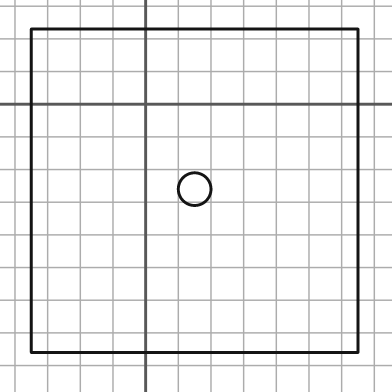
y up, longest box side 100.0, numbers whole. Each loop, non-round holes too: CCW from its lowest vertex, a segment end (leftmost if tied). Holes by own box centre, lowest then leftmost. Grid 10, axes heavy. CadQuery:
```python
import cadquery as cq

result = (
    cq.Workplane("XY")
    .moveTo(-35.0, -76.0)
    .lineTo(65.0, -76.0)
    .lineTo(65.0, 23.0)
    .lineTo(-35.0, 23.0)
    .close()
    .moveTo(15.0, -26.0)
    .circle(5.0)
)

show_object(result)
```